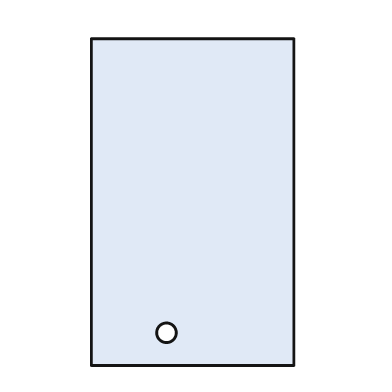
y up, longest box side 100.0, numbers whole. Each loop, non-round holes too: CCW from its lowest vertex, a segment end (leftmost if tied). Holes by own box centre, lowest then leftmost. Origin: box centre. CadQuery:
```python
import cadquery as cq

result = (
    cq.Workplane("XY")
    .moveTo(-31.0, -50.0)
    .lineTo(31.0, -50.0)
    .lineTo(31.0, 50.0)
    .lineTo(-31.0, 50.0)
    .close()
    .moveTo(-8.0, -40.0)
    .circle(3.0)
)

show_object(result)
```